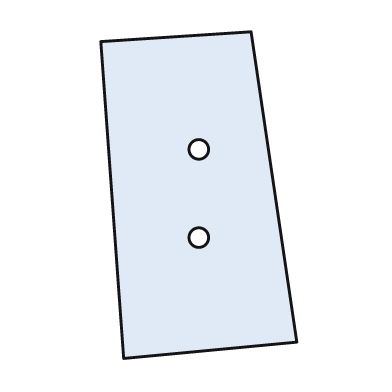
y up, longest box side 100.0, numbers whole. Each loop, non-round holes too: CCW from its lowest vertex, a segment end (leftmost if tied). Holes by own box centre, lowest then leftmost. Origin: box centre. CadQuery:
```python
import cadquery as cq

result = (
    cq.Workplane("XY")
    .moveTo(-23.0, -50.0)
    .lineTo(30.0, -45.0)
    .lineTo(16.0, 50.0)
    .lineTo(-30.0, 47.0)
    .close()
    .moveTo(0.0, -13.0)
    .circle(3.0)
    .moveTo(0.0, 14.0)
    .circle(3.0)
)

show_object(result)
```